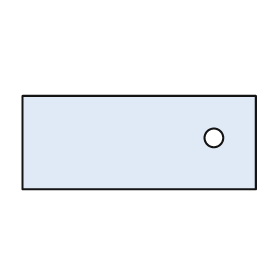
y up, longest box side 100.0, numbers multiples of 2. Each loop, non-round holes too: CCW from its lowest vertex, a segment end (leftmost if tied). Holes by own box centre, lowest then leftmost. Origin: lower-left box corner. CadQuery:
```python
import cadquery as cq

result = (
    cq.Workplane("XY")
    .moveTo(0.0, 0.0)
    .lineTo(100.0, 0.0)
    .lineTo(100.0, 40.0)
    .lineTo(0.0, 40.0)
    .close()
    .moveTo(82.0, 22.0)
    .circle(4.0)
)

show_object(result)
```